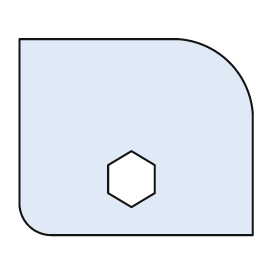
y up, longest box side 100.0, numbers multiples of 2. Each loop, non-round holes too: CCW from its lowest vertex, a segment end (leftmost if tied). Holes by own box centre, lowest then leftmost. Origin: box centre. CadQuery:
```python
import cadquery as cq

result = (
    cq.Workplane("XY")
    .moveTo(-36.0, -42.0)
    .lineTo(50.0, -42.0)
    .lineTo(50.0, 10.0)
    .threePointArc((40.0, 32.0), (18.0, 42.0))
    .lineTo(-50.0, 42.0)
    .lineTo(-50.0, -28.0)
    .threePointArc((-46.0, -38.0), (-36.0, -42.0))
    .close()
    .moveTo(-2.0, -30.0)
    .lineTo(8.0, -24.0)
    .lineTo(8.0, -12.0)
    .lineTo(-2.0, -6.0)
    .lineTo(-12.0, -12.0)
    .lineTo(-12.0, -24.0)
    .close()
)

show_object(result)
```